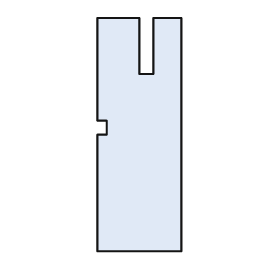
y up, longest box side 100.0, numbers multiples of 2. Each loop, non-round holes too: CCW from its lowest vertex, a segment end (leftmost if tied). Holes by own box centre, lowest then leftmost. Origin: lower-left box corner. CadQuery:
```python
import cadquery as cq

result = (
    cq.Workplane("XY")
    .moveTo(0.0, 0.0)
    .lineTo(36.0, 0.0)
    .lineTo(36.0, 100.0)
    .lineTo(24.0, 100.0)
    .lineTo(24.0, 76.0)
    .lineTo(18.0, 76.0)
    .lineTo(18.0, 100.0)
    .lineTo(0.0, 100.0)
    .lineTo(0.0, 56.0)
    .lineTo(4.0, 56.0)
    .lineTo(4.0, 50.0)
    .lineTo(0.0, 50.0)
    .close()
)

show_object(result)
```